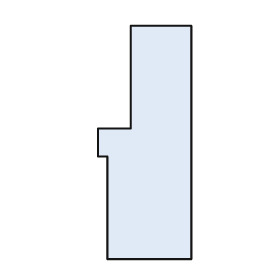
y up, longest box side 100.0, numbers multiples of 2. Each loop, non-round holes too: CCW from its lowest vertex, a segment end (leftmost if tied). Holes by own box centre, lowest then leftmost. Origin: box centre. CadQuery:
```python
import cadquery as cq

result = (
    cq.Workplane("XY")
    .moveTo(-16.0, -50.0)
    .lineTo(20.0, -50.0)
    .lineTo(20.0, 50.0)
    .lineTo(-6.0, 50.0)
    .lineTo(-6.0, 6.0)
    .lineTo(-20.0, 6.0)
    .lineTo(-20.0, -6.0)
    .lineTo(-16.0, -6.0)
    .close()
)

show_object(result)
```